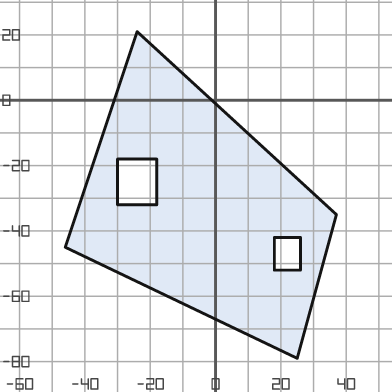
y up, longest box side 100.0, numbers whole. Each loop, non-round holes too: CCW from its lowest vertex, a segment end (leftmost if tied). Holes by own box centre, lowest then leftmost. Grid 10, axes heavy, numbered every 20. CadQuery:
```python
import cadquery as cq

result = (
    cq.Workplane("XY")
    .moveTo(25.0, -79.0)
    .lineTo(37.0, -35.0)
    .lineTo(-24.0, 21.0)
    .lineTo(-46.0, -45.0)
    .close()
    .moveTo(18.0, -52.0)
    .lineTo(26.0, -52.0)
    .lineTo(26.0, -42.0)
    .lineTo(18.0, -42.0)
    .close()
    .moveTo(-30.0, -32.0)
    .lineTo(-18.0, -32.0)
    .lineTo(-18.0, -18.0)
    .lineTo(-30.0, -18.0)
    .close()
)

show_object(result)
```